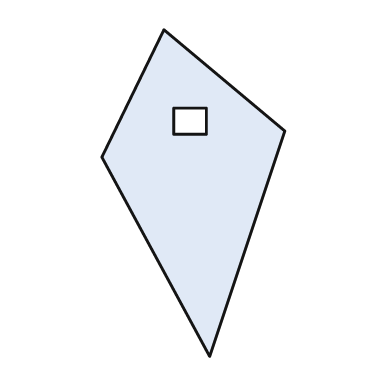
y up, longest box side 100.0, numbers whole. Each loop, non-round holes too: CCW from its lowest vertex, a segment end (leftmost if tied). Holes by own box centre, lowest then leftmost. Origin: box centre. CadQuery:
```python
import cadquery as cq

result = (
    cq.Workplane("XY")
    .moveTo(5.0, -50.0)
    .lineTo(28.0, 19.0)
    .lineTo(-9.0, 50.0)
    .lineTo(-28.0, 11.0)
    .close()
    .moveTo(-6.0, 18.0)
    .lineTo(4.0, 18.0)
    .lineTo(4.0, 26.0)
    .lineTo(-6.0, 26.0)
    .close()
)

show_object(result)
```